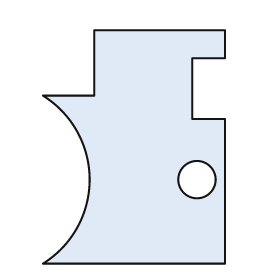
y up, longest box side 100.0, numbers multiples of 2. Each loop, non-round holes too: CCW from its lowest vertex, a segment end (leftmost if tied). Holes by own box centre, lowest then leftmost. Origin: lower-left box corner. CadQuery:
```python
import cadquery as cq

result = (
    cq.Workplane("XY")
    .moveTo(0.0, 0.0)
    .lineTo(78.0, 0.0)
    .lineTo(78.0, 62.0)
    .lineTo(64.0, 62.0)
    .lineTo(64.0, 88.0)
    .lineTo(78.0, 88.0)
    .lineTo(78.0, 100.0)
    .lineTo(22.0, 100.0)
    .lineTo(22.0, 72.0)
    .lineTo(0.0, 72.0)
    .threePointArc((20.0, 36.0), (0.0, 0.0))
    .close()
    .moveTo(66.0, 36.0)
    .circle(8.0)
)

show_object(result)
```